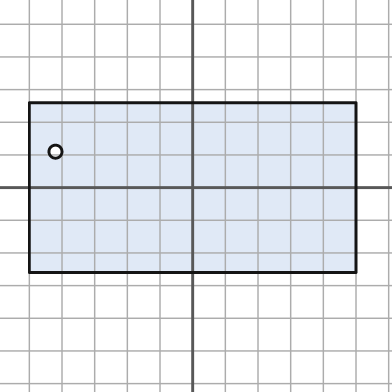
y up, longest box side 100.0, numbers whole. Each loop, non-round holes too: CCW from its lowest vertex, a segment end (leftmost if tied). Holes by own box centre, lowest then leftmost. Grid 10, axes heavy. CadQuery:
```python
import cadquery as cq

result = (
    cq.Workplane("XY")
    .moveTo(-50.0, -26.0)
    .lineTo(50.0, -26.0)
    .lineTo(50.0, 26.0)
    .lineTo(-50.0, 26.0)
    .close()
    .moveTo(-42.0, 11.0)
    .circle(2.0)
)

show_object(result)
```